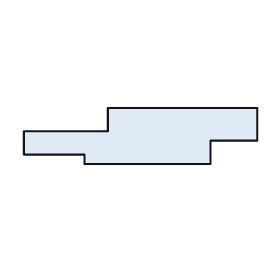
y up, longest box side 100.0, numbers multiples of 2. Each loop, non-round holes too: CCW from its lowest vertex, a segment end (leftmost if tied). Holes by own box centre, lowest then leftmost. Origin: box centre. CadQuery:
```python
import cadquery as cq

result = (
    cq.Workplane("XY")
    .moveTo(-24.0, -12.0)
    .lineTo(30.0, -12.0)
    .lineTo(30.0, -2.0)
    .lineTo(50.0, -2.0)
    .lineTo(50.0, 12.0)
    .lineTo(-14.0, 12.0)
    .lineTo(-14.0, 2.0)
    .lineTo(-50.0, 2.0)
    .lineTo(-50.0, -8.0)
    .lineTo(-24.0, -8.0)
    .close()
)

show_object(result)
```